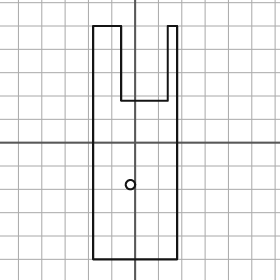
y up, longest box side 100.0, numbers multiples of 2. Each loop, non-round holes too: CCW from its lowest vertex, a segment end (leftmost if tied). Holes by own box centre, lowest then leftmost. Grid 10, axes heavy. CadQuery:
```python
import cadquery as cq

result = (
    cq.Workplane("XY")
    .moveTo(-18.0, -50.0)
    .lineTo(18.0, -50.0)
    .lineTo(18.0, 50.0)
    .lineTo(14.0, 50.0)
    .lineTo(14.0, 18.0)
    .lineTo(-6.0, 18.0)
    .lineTo(-6.0, 50.0)
    .lineTo(-18.0, 50.0)
    .close()
    .moveTo(-2.0, -18.0)
    .circle(2.0)
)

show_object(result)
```